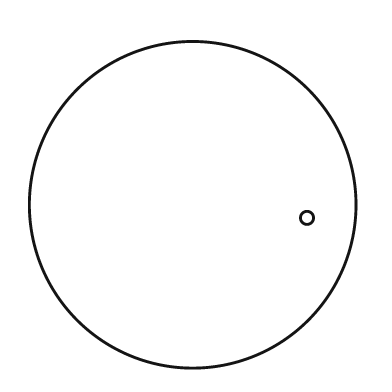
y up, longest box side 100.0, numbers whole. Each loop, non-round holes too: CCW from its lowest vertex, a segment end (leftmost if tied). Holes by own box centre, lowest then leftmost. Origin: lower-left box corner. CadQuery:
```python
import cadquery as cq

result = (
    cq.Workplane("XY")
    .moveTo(50.0, 50.0)
    .circle(50.0)
    .moveTo(85.0, 46.0)
    .circle(2.0)
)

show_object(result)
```